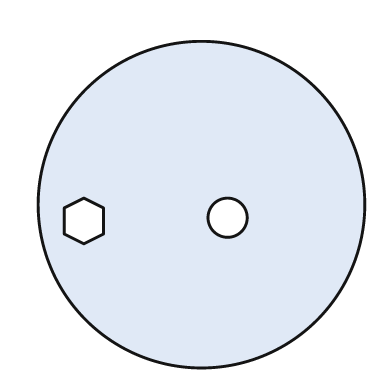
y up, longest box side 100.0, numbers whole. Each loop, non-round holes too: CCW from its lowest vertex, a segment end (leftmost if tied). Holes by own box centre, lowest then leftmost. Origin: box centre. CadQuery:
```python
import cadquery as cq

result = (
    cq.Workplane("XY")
    .moveTo(0.0, 0.0)
    .circle(50.0)
    .moveTo(-36.0, -12.0)
    .lineTo(-30.0, -9.0)
    .lineTo(-30.0, -1.0)
    .lineTo(-36.0, 2.0)
    .lineTo(-42.0, -1.0)
    .lineTo(-42.0, -9.0)
    .close()
    .moveTo(8.0, -4.0)
    .circle(6.0)
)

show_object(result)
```